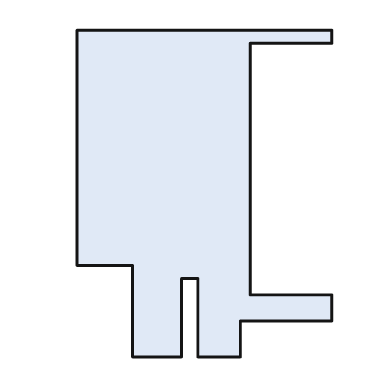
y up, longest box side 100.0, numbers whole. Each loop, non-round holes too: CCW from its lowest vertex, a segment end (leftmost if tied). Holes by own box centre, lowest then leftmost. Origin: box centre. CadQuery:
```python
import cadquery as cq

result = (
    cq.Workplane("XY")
    .moveTo(-22.0, -50.0)
    .lineTo(-7.0, -50.0)
    .lineTo(-7.0, -26.0)
    .lineTo(-2.0, -26.0)
    .lineTo(-2.0, -50.0)
    .lineTo(11.0, -50.0)
    .lineTo(11.0, -39.0)
    .lineTo(39.0, -39.0)
    .lineTo(39.0, -31.0)
    .lineTo(14.0, -31.0)
    .lineTo(14.0, 46.0)
    .lineTo(39.0, 46.0)
    .lineTo(39.0, 50.0)
    .lineTo(-39.0, 50.0)
    .lineTo(-39.0, -22.0)
    .lineTo(-22.0, -22.0)
    .close()
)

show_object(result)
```